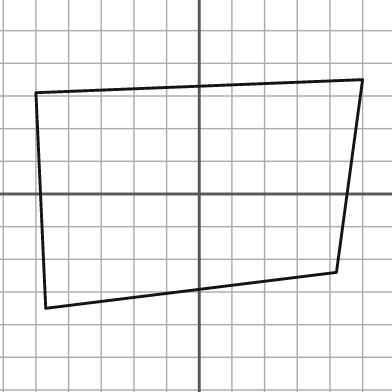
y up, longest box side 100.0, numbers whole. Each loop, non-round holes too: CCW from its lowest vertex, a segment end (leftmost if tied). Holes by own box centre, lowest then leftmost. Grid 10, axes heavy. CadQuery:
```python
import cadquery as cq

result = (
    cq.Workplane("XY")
    .moveTo(-47.0, -35.0)
    .lineTo(42.0, -24.0)
    .lineTo(50.0, 35.0)
    .lineTo(-50.0, 31.0)
    .close()
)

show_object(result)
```